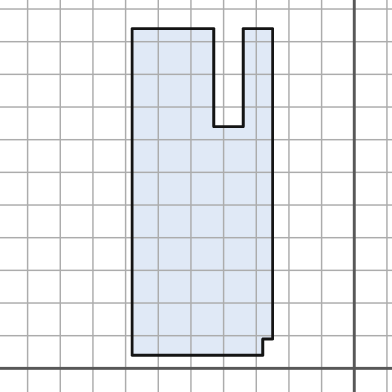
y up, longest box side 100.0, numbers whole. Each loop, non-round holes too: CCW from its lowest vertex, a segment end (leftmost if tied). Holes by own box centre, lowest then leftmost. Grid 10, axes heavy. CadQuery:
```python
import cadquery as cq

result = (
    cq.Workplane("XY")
    .moveTo(-68.0, 4.0)
    .lineTo(-28.0, 4.0)
    .lineTo(-28.0, 9.0)
    .lineTo(-25.0, 9.0)
    .lineTo(-25.0, 104.0)
    .lineTo(-34.0, 104.0)
    .lineTo(-34.0, 74.0)
    .lineTo(-43.0, 74.0)
    .lineTo(-43.0, 104.0)
    .lineTo(-68.0, 104.0)
    .close()
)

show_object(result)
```